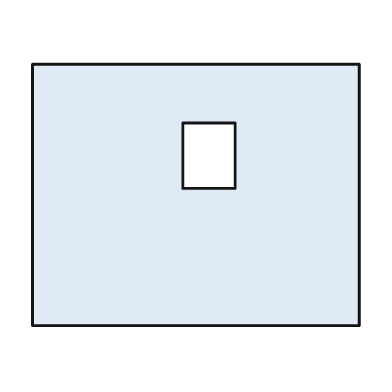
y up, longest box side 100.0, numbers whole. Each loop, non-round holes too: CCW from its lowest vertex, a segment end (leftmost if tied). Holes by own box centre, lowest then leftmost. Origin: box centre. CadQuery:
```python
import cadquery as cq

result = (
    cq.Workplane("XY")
    .moveTo(-50.0, -40.0)
    .lineTo(50.0, -40.0)
    .lineTo(50.0, 40.0)
    .lineTo(-50.0, 40.0)
    .close()
    .moveTo(-4.0, 2.0)
    .lineTo(12.0, 2.0)
    .lineTo(12.0, 22.0)
    .lineTo(-4.0, 22.0)
    .close()
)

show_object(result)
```